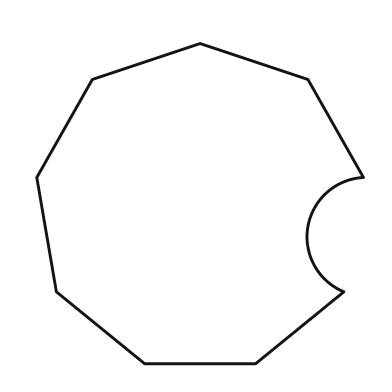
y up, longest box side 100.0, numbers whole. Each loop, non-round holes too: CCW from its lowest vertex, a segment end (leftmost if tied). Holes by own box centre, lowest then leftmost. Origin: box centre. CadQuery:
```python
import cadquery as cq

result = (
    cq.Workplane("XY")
    .moveTo(-17.0, -49.0)
    .lineTo(17.0, -49.0)
    .lineTo(44.0, -27.0)
    .threePointArc((33.0, -7.0), (50.0, 8.0))
    .lineTo(33.0, 38.0)
    .lineTo(0.0, 49.0)
    .lineTo(-33.0, 38.0)
    .lineTo(-50.0, 8.0)
    .lineTo(-44.0, -27.0)
    .close()
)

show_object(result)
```